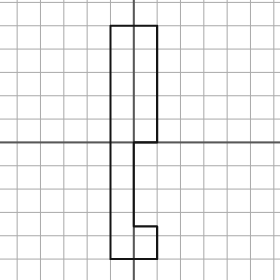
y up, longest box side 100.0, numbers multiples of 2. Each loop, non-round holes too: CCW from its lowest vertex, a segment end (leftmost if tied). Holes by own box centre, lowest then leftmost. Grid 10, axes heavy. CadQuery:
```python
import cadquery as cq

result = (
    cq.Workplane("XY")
    .moveTo(-10.0, -50.0)
    .lineTo(10.0, -50.0)
    .lineTo(10.0, -36.0)
    .lineTo(0.0, -36.0)
    .lineTo(0.0, 0.0)
    .lineTo(10.0, 0.0)
    .lineTo(10.0, 50.0)
    .lineTo(-10.0, 50.0)
    .close()
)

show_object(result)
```